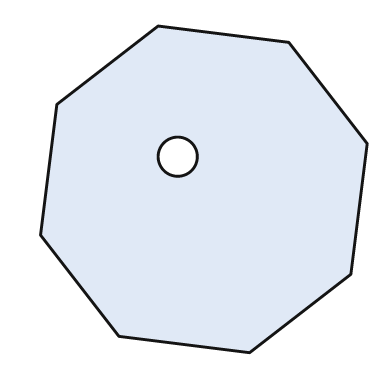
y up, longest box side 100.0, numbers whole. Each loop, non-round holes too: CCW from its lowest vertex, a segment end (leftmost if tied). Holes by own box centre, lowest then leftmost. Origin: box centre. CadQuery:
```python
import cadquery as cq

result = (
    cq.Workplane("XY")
    .moveTo(14.0, -50.0)
    .lineTo(45.0, -26.0)
    .lineTo(50.0, 14.0)
    .lineTo(26.0, 45.0)
    .lineTo(-14.0, 50.0)
    .lineTo(-45.0, 26.0)
    .lineTo(-50.0, -14.0)
    .lineTo(-26.0, -45.0)
    .close()
    .moveTo(-8.0, 10.0)
    .circle(6.0)
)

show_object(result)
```